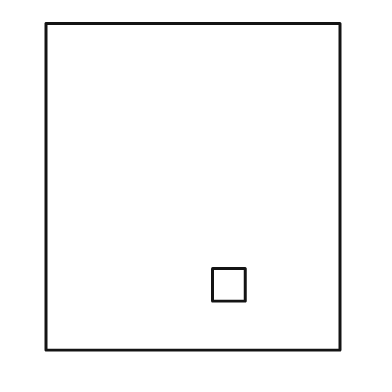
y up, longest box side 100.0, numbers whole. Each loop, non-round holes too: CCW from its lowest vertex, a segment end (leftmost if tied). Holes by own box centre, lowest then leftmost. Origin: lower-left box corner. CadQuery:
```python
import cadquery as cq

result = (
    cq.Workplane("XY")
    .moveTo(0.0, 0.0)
    .lineTo(90.0, 0.0)
    .lineTo(90.0, 100.0)
    .lineTo(0.0, 100.0)
    .close()
    .moveTo(51.0, 15.0)
    .lineTo(61.0, 15.0)
    .lineTo(61.0, 25.0)
    .lineTo(51.0, 25.0)
    .close()
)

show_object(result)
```